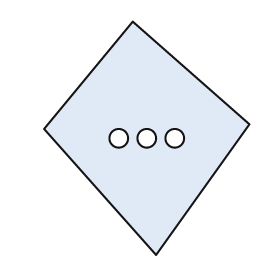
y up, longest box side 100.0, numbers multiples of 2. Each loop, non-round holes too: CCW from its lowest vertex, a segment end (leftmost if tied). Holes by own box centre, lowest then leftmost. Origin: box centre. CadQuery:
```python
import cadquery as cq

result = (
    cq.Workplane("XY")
    .moveTo(4.0, -50.0)
    .lineTo(44.0, 6.0)
    .lineTo(-6.0, 50.0)
    .lineTo(-44.0, 4.0)
    .close()
    .moveTo(-12.0, 0.0)
    .circle(4.0)
    .moveTo(0.0, 0.0)
    .circle(4.0)
    .moveTo(12.0, 0.0)
    .circle(4.0)
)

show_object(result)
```